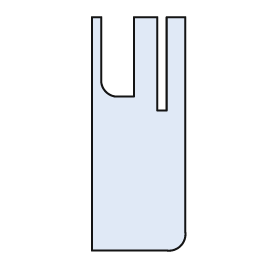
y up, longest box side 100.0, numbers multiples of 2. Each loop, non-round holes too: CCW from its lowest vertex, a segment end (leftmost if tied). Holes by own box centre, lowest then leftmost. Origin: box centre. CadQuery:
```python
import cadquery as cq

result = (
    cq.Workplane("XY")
    .moveTo(-20.0, -50.0)
    .lineTo(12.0, -50.0)
    .threePointArc((18.0, -48.0), (20.0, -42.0))
    .lineTo(20.0, 50.0)
    .lineTo(12.0, 50.0)
    .lineTo(12.0, 10.0)
    .lineTo(8.0, 10.0)
    .lineTo(8.0, 50.0)
    .lineTo(-2.0, 50.0)
    .lineTo(-2.0, 16.0)
    .lineTo(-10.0, 16.0)
    .threePointArc((-14.0, 18.0), (-16.0, 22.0))
    .lineTo(-16.0, 50.0)
    .lineTo(-20.0, 50.0)
    .close()
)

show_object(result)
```